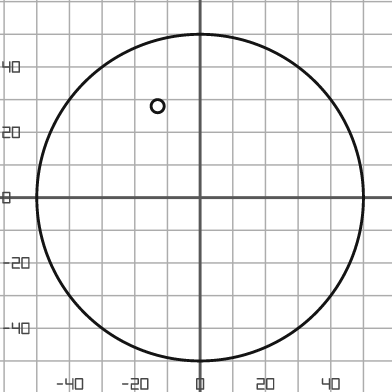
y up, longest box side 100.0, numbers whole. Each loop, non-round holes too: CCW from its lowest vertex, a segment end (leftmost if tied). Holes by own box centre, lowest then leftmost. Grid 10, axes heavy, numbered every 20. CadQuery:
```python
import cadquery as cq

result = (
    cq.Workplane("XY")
    .moveTo(0.0, 0.0)
    .circle(50.0)
    .moveTo(-13.0, 28.0)
    .circle(2.0)
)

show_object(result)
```